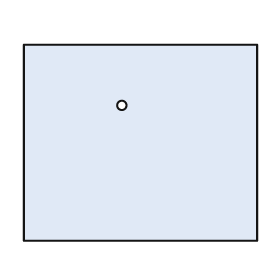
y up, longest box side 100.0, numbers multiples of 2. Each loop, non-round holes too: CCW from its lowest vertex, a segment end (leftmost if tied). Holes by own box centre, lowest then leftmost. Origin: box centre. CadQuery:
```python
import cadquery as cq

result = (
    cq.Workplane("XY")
    .moveTo(-50.0, -42.0)
    .lineTo(50.0, -42.0)
    .lineTo(50.0, 42.0)
    .lineTo(-50.0, 42.0)
    .close()
    .moveTo(-8.0, 16.0)
    .circle(2.0)
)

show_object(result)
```